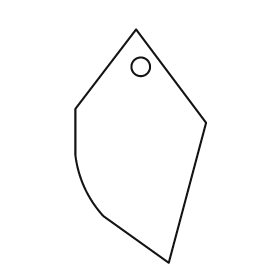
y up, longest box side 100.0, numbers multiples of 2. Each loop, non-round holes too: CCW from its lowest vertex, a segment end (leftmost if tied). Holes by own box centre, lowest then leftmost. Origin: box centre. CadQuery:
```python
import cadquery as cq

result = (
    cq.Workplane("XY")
    .moveTo(12.0, -50.0)
    .lineTo(28.0, 10.0)
    .lineTo(-2.0, 50.0)
    .lineTo(-28.0, 16.0)
    .lineTo(-28.0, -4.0)
    .threePointArc((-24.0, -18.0), (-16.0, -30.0))
    .close()
    .moveTo(0.0, 34.0)
    .circle(4.0)
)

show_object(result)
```